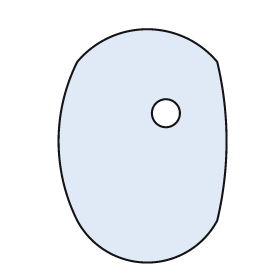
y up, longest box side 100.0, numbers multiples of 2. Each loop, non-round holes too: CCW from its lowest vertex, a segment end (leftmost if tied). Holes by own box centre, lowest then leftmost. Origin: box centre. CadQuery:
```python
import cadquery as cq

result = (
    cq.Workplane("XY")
    .moveTo(-28.0, -32.0)
    .threePointArc((2.0, -50.0), (32.0, -32.0))
    .threePointArc((36.0, 2.0), (32.0, 36.0))
    .threePointArc((2.0, 50.0), (-28.0, 36.0))
    .threePointArc((-36.0, 2.0), (-28.0, -32.0))
    .close()
    .moveTo(10.0, 14.0)
    .circle(6.0)
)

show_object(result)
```